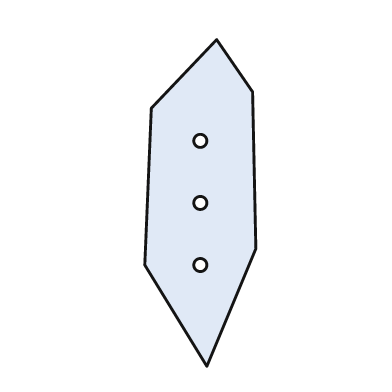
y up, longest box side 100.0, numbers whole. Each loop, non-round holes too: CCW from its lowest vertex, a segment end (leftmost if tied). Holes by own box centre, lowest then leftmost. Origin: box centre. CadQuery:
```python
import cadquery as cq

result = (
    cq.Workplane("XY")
    .moveTo(2.0, -50.0)
    .lineTo(17.0, -14.0)
    .lineTo(16.0, 34.0)
    .lineTo(5.0, 50.0)
    .lineTo(-15.0, 29.0)
    .lineTo(-17.0, -19.0)
    .close()
    .moveTo(0.0, -19.0)
    .circle(2.0)
    .moveTo(0.0, 0.0)
    .circle(2.0)
    .moveTo(0.0, 19.0)
    .circle(2.0)
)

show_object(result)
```